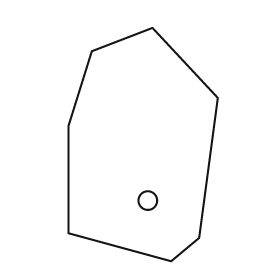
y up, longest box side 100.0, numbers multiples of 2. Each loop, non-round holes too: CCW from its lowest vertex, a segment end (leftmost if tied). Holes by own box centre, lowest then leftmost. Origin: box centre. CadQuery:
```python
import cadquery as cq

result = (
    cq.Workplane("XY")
    .moveTo(12.0, -50.0)
    .lineTo(24.0, -40.0)
    .lineTo(32.0, 20.0)
    .lineTo(4.0, 50.0)
    .lineTo(-22.0, 40.0)
    .lineTo(-32.0, 8.0)
    .lineTo(-32.0, -38.0)
    .close()
    .moveTo(2.0, -24.0)
    .circle(4.0)
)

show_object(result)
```